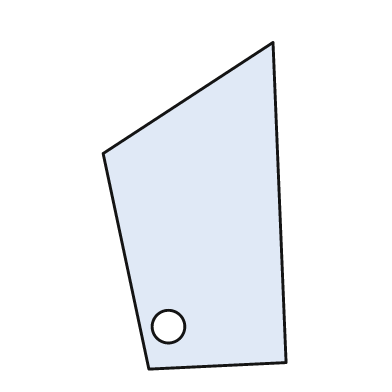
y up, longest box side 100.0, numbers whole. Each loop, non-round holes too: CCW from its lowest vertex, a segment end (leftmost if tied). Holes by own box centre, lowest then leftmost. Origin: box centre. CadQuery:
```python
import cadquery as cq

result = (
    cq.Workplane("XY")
    .moveTo(-14.0, -50.0)
    .lineTo(28.0, -48.0)
    .lineTo(24.0, 50.0)
    .lineTo(-28.0, 16.0)
    .close()
    .moveTo(-8.0, -37.0)
    .circle(5.0)
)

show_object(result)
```